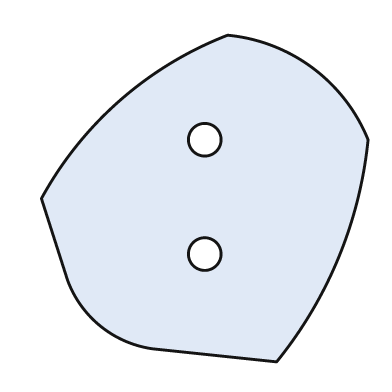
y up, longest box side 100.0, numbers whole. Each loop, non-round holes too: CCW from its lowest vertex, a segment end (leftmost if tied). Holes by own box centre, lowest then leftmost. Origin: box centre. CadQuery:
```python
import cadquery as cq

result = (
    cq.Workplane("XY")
    .moveTo(22.0, -50.0)
    .threePointArc((41.0, -18.0), (50.0, 18.0))
    .threePointArc((33.0, 40.0), (7.0, 50.0))
    .threePointArc((-26.0, 30.0), (-50.0, 0.0))
    .lineTo(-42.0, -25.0)
    .threePointArc((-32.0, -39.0), (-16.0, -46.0))
    .close()
    .moveTo(0.0, -17.0)
    .circle(5.0)
    .moveTo(0.0, 18.0)
    .circle(5.0)
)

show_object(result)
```